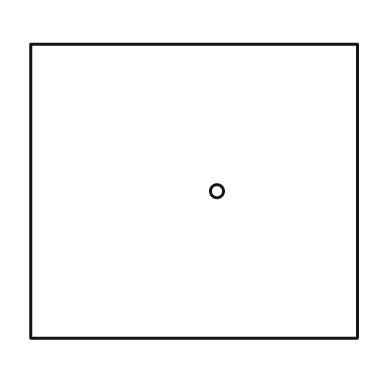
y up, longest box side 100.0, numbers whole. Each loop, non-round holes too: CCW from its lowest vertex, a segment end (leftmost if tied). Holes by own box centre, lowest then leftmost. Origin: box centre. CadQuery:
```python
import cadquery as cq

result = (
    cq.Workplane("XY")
    .moveTo(-50.0, -45.0)
    .lineTo(50.0, -45.0)
    .lineTo(50.0, 45.0)
    .lineTo(-50.0, 45.0)
    .close()
    .moveTo(7.0, 0.0)
    .circle(2.0)
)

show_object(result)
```